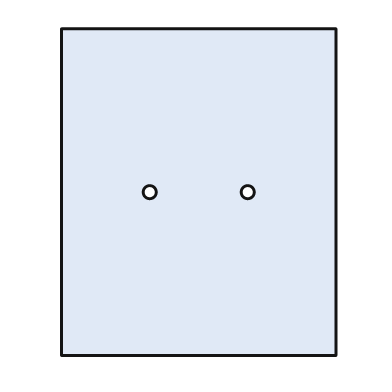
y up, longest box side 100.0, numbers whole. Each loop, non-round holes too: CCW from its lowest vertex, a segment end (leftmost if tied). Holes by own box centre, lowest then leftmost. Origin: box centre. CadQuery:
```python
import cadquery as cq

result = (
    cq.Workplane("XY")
    .moveTo(-42.0, -50.0)
    .lineTo(42.0, -50.0)
    .lineTo(42.0, 50.0)
    .lineTo(-42.0, 50.0)
    .close()
    .moveTo(-15.0, 0.0)
    .circle(2.0)
    .moveTo(15.0, 0.0)
    .circle(2.0)
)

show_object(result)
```